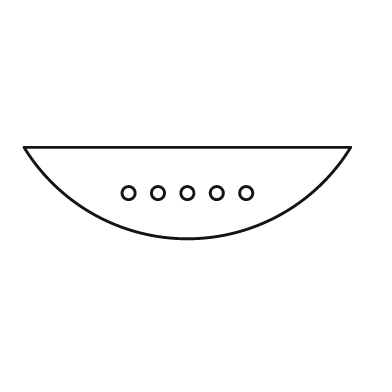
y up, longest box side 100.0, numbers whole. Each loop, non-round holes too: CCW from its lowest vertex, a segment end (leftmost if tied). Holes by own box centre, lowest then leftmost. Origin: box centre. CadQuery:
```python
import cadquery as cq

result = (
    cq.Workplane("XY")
    .moveTo(-50.0, 14.0)
    .threePointArc((0.0, -14.0), (50.0, 14.0))
    .close()
    .moveTo(-18.0, 0.0)
    .circle(2.0)
    .moveTo(-9.0, 0.0)
    .circle(2.0)
    .moveTo(0.0, 0.0)
    .circle(2.0)
    .moveTo(9.0, 0.0)
    .circle(2.0)
    .moveTo(18.0, 0.0)
    .circle(2.0)
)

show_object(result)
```